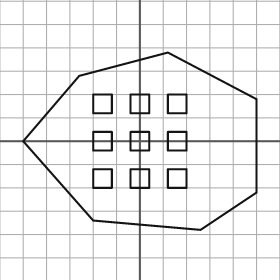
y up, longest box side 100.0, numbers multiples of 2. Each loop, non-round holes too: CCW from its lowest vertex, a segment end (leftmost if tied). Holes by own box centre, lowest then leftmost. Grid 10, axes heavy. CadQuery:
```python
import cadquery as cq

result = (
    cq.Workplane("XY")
    .moveTo(26.0, -38.0)
    .lineTo(50.0, -22.0)
    .lineTo(50.0, 18.0)
    .lineTo(12.0, 38.0)
    .lineTo(-26.0, 28.0)
    .lineTo(-50.0, 0.0)
    .lineTo(-20.0, -34.0)
    .close()
    .moveTo(-20.0, -20.0)
    .lineTo(-12.0, -20.0)
    .lineTo(-12.0, -12.0)
    .lineTo(-20.0, -12.0)
    .close()
    .moveTo(-4.0, -20.0)
    .lineTo(4.0, -20.0)
    .lineTo(4.0, -12.0)
    .lineTo(-4.0, -12.0)
    .close()
    .moveTo(12.0, -20.0)
    .lineTo(20.0, -20.0)
    .lineTo(20.0, -12.0)
    .lineTo(12.0, -12.0)
    .close()
    .moveTo(-20.0, -4.0)
    .lineTo(-12.0, -4.0)
    .lineTo(-12.0, 4.0)
    .lineTo(-20.0, 4.0)
    .close()
    .moveTo(-4.0, -4.0)
    .lineTo(4.0, -4.0)
    .lineTo(4.0, 4.0)
    .lineTo(-4.0, 4.0)
    .close()
    .moveTo(12.0, -4.0)
    .lineTo(20.0, -4.0)
    .lineTo(20.0, 4.0)
    .lineTo(12.0, 4.0)
    .close()
    .moveTo(-20.0, 12.0)
    .lineTo(-12.0, 12.0)
    .lineTo(-12.0, 20.0)
    .lineTo(-20.0, 20.0)
    .close()
    .moveTo(-4.0, 12.0)
    .lineTo(4.0, 12.0)
    .lineTo(4.0, 20.0)
    .lineTo(-4.0, 20.0)
    .close()
    .moveTo(12.0, 12.0)
    .lineTo(20.0, 12.0)
    .lineTo(20.0, 20.0)
    .lineTo(12.0, 20.0)
    .close()
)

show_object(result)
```